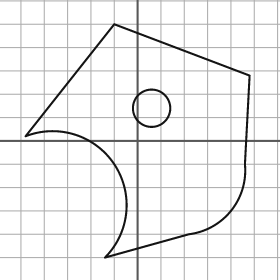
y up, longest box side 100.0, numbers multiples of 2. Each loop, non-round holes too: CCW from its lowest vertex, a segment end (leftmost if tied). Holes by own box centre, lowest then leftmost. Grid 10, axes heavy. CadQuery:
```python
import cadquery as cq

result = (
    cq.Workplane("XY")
    .moveTo(-14.0, -50.0)
    .lineTo(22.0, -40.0)
    .threePointArc((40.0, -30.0), (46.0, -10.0))
    .lineTo(48.0, 28.0)
    .lineTo(-10.0, 50.0)
    .lineTo(-48.0, 2.0)
    .threePointArc((-10.0, -10.0), (-14.0, -50.0))
    .close()
    .moveTo(6.0, 14.0)
    .circle(8.0)
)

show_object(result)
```